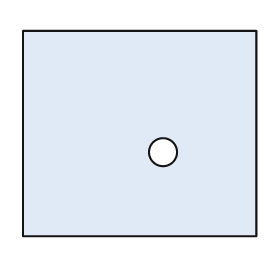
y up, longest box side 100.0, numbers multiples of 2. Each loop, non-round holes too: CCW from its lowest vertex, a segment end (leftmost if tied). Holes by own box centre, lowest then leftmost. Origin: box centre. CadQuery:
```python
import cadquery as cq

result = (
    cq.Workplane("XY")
    .moveTo(-50.0, -44.0)
    .lineTo(50.0, -44.0)
    .lineTo(50.0, 44.0)
    .lineTo(-50.0, 44.0)
    .close()
    .moveTo(10.0, -8.0)
    .circle(6.0)
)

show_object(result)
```